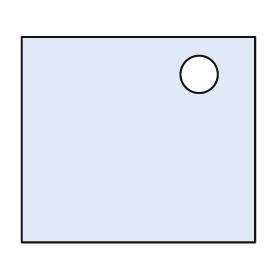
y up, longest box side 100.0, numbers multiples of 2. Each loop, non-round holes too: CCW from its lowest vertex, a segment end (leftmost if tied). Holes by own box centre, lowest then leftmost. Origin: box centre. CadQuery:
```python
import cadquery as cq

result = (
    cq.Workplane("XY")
    .moveTo(-50.0, -44.0)
    .lineTo(50.0, -44.0)
    .lineTo(50.0, 44.0)
    .lineTo(-50.0, 44.0)
    .close()
    .moveTo(26.0, 28.0)
    .circle(8.0)
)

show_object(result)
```